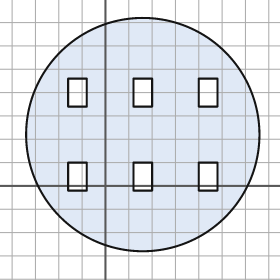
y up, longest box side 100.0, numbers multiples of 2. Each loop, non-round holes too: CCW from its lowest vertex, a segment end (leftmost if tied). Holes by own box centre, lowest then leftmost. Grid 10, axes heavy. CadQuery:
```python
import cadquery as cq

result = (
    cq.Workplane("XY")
    .moveTo(16.0, 22.0)
    .circle(50.0)
    .moveTo(-16.0, -2.0)
    .lineTo(-8.0, -2.0)
    .lineTo(-8.0, 10.0)
    .lineTo(-16.0, 10.0)
    .close()
    .moveTo(12.0, -2.0)
    .lineTo(20.0, -2.0)
    .lineTo(20.0, 10.0)
    .lineTo(12.0, 10.0)
    .close()
    .moveTo(40.0, -2.0)
    .lineTo(48.0, -2.0)
    .lineTo(48.0, 10.0)
    .lineTo(40.0, 10.0)
    .close()
    .moveTo(-16.0, 34.0)
    .lineTo(-8.0, 34.0)
    .lineTo(-8.0, 46.0)
    .lineTo(-16.0, 46.0)
    .close()
    .moveTo(12.0, 34.0)
    .lineTo(20.0, 34.0)
    .lineTo(20.0, 46.0)
    .lineTo(12.0, 46.0)
    .close()
    .moveTo(40.0, 34.0)
    .lineTo(48.0, 34.0)
    .lineTo(48.0, 46.0)
    .lineTo(40.0, 46.0)
    .close()
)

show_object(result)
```